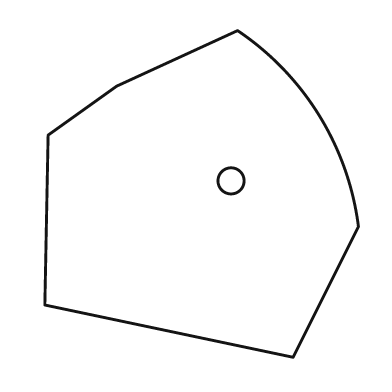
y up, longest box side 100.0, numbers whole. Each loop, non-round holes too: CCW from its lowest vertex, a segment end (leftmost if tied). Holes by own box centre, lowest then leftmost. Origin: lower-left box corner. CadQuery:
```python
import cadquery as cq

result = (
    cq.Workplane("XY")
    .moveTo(76.0, 0.0)
    .lineTo(96.0, 40.0)
    .threePointArc((84.0, 74.0), (59.0, 100.0))
    .lineTo(22.0, 83.0)
    .lineTo(1.0, 68.0)
    .lineTo(0.0, 16.0)
    .close()
    .moveTo(57.0, 54.0)
    .circle(4.0)
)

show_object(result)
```